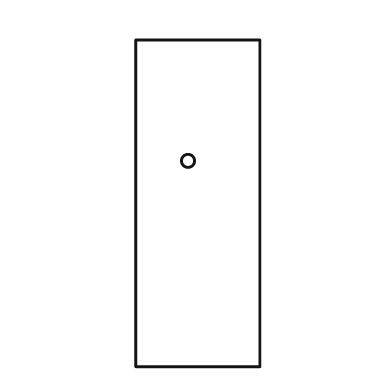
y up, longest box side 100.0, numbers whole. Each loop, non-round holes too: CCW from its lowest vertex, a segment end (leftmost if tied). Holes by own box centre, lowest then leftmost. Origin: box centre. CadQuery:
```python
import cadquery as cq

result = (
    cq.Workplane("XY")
    .moveTo(-19.0, -50.0)
    .lineTo(19.0, -50.0)
    .lineTo(19.0, 50.0)
    .lineTo(-19.0, 50.0)
    .close()
    .moveTo(-3.0, 13.0)
    .circle(2.0)
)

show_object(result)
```